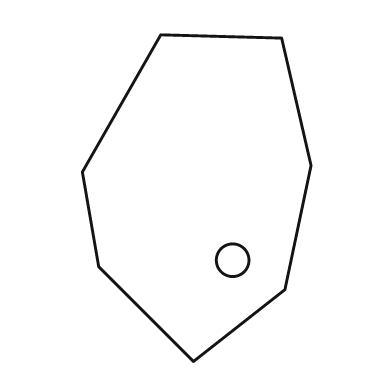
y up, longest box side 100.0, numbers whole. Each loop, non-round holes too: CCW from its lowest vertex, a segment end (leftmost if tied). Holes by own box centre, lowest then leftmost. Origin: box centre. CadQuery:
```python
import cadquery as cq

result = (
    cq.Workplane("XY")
    .moveTo(-1.0, -50.0)
    .lineTo(27.0, -28.0)
    .lineTo(35.0, 10.0)
    .lineTo(26.0, 49.0)
    .lineTo(-11.0, 50.0)
    .lineTo(-35.0, 8.0)
    .lineTo(-30.0, -21.0)
    .close()
    .moveTo(11.0, -19.0)
    .circle(5.0)
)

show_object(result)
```